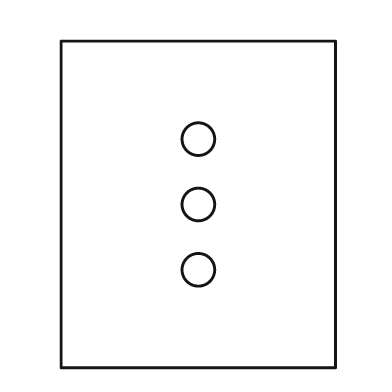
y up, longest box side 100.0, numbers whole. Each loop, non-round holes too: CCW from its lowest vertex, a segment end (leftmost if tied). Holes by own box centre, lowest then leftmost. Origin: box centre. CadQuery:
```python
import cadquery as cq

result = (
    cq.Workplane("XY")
    .moveTo(-42.0, -50.0)
    .lineTo(42.0, -50.0)
    .lineTo(42.0, 50.0)
    .lineTo(-42.0, 50.0)
    .close()
    .moveTo(0.0, -20.0)
    .circle(5.0)
    .moveTo(0.0, 0.0)
    .circle(5.0)
    .moveTo(0.0, 20.0)
    .circle(5.0)
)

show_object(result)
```